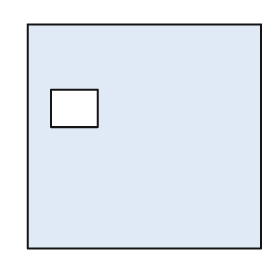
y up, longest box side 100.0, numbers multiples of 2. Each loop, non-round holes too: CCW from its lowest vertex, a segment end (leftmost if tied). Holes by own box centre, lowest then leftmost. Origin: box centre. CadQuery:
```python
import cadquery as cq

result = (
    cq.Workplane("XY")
    .moveTo(-50.0, -48.0)
    .lineTo(50.0, -48.0)
    .lineTo(50.0, 48.0)
    .lineTo(-50.0, 48.0)
    .close()
    .moveTo(-40.0, 4.0)
    .lineTo(-20.0, 4.0)
    .lineTo(-20.0, 20.0)
    .lineTo(-40.0, 20.0)
    .close()
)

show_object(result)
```